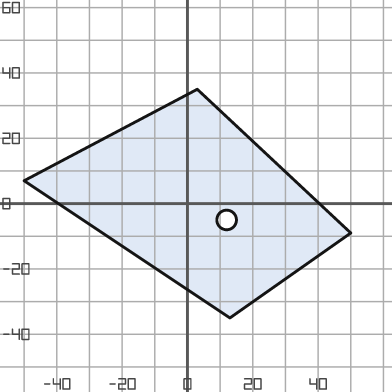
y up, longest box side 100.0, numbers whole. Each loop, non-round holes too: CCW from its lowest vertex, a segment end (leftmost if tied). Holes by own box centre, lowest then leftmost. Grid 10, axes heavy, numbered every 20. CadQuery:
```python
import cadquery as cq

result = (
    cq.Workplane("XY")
    .moveTo(13.0, -35.0)
    .lineTo(50.0, -9.0)
    .lineTo(3.0, 35.0)
    .lineTo(-50.0, 7.0)
    .close()
    .moveTo(12.0, -5.0)
    .circle(3.0)
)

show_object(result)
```